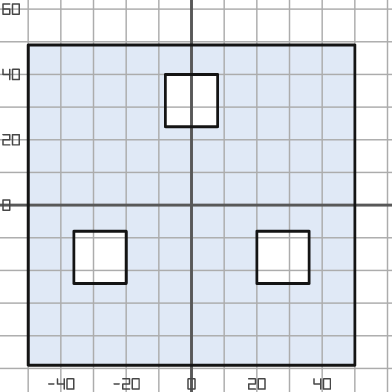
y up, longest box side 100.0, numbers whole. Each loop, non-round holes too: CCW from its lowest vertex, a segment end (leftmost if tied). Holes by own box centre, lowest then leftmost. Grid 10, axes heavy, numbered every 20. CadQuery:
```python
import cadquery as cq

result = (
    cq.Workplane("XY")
    .moveTo(-50.0, -49.0)
    .lineTo(50.0, -49.0)
    .lineTo(50.0, 49.0)
    .lineTo(-50.0, 49.0)
    .close()
    .moveTo(-36.0, -24.0)
    .lineTo(-20.0, -24.0)
    .lineTo(-20.0, -8.0)
    .lineTo(-36.0, -8.0)
    .close()
    .moveTo(20.0, -24.0)
    .lineTo(36.0, -24.0)
    .lineTo(36.0, -8.0)
    .lineTo(20.0, -8.0)
    .close()
    .moveTo(-8.0, 24.0)
    .lineTo(8.0, 24.0)
    .lineTo(8.0, 40.0)
    .lineTo(-8.0, 40.0)
    .close()
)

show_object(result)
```